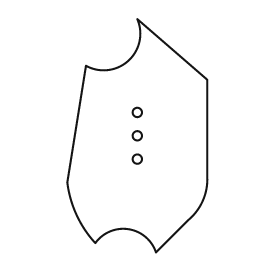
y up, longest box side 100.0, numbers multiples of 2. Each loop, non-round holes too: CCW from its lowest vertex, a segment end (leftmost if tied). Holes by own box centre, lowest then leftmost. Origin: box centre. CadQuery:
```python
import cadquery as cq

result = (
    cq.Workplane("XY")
    .moveTo(8.0, -50.0)
    .lineTo(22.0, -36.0)
    .threePointArc((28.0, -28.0), (30.0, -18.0))
    .lineTo(30.0, 24.0)
    .lineTo(0.0, 50.0)
    .threePointArc((-4.0, 32.0), (-22.0, 30.0))
    .lineTo(-30.0, -20.0)
    .threePointArc((-26.0, -34.0), (-18.0, -46.0))
    .threePointArc((-4.0, -40.0), (8.0, -50.0))
    .close()
    .moveTo(0.0, -10.0)
    .circle(2.0)
    .moveTo(0.0, 0.0)
    .circle(2.0)
    .moveTo(0.0, 10.0)
    .circle(2.0)
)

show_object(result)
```